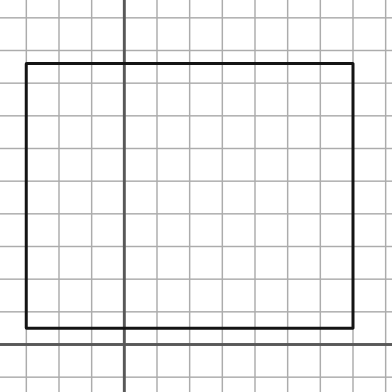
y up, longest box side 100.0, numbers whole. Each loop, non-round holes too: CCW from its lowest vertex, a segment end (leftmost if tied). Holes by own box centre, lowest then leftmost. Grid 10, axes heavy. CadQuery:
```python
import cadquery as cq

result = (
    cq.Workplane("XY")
    .moveTo(-30.0, 5.0)
    .lineTo(70.0, 5.0)
    .lineTo(70.0, 86.0)
    .lineTo(-30.0, 86.0)
    .close()
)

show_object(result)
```